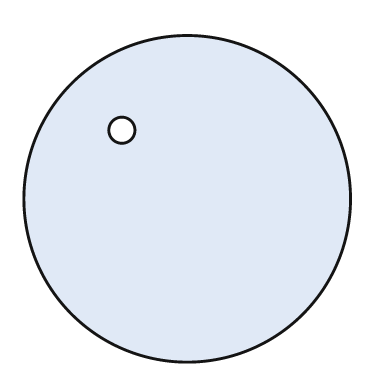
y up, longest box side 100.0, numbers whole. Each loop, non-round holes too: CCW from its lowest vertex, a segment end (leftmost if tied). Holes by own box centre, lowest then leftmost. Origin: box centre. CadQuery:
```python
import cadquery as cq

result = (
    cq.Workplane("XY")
    .moveTo(0.0, 0.0)
    .circle(50.0)
    .moveTo(-20.0, 21.0)
    .circle(4.0)
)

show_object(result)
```